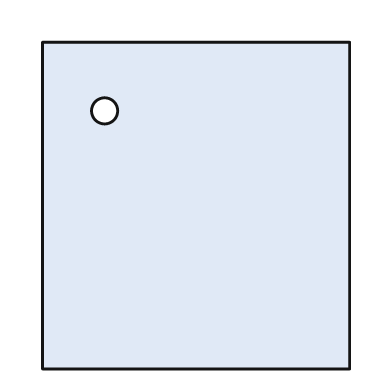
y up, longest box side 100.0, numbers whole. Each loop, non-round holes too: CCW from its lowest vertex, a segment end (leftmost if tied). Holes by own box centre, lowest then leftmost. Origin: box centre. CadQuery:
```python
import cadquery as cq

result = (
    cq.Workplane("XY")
    .moveTo(-47.0, -50.0)
    .lineTo(47.0, -50.0)
    .lineTo(47.0, 50.0)
    .lineTo(-47.0, 50.0)
    .close()
    .moveTo(-28.0, 29.0)
    .circle(4.0)
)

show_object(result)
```